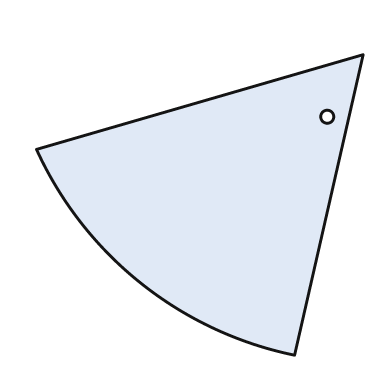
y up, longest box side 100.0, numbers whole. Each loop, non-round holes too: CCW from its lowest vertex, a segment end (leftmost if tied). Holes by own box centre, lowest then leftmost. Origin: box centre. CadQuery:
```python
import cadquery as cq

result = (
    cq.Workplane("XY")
    .moveTo(29.0, -46.0)
    .lineTo(50.0, 46.0)
    .lineTo(-50.0, 17.0)
    .threePointArc((-18.0, -24.0), (29.0, -46.0))
    .close()
    .moveTo(39.0, 27.0)
    .circle(2.0)
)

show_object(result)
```